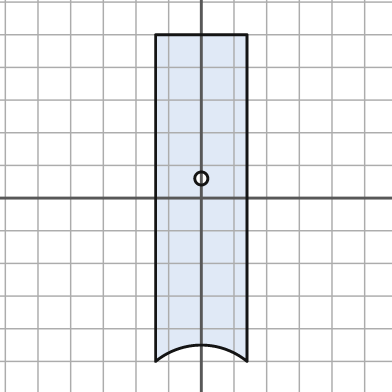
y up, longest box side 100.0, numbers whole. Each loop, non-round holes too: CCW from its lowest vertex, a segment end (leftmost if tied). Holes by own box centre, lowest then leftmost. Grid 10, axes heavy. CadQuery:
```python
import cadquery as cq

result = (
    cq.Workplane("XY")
    .moveTo(-14.0, -50.0)
    .threePointArc((0.0, -45.0), (14.0, -50.0))
    .lineTo(14.0, 50.0)
    .lineTo(-14.0, 50.0)
    .close()
    .moveTo(0.0, 6.0)
    .circle(2.0)
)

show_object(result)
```